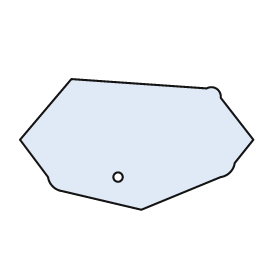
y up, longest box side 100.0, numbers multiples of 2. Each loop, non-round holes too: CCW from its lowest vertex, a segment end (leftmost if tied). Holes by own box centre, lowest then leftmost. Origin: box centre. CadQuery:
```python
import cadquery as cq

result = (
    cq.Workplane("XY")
    .moveTo(2.0, -28.0)
    .lineTo(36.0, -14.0)
    .threePointArc((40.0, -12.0), (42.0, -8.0))
    .lineTo(50.0, 2.0)
    .lineTo(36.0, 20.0)
    .threePointArc((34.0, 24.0), (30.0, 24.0))
    .lineTo(-28.0, 28.0)
    .lineTo(-50.0, 2.0)
    .lineTo(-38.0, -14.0)
    .threePointArc((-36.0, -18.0), (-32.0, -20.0))
    .close()
    .moveTo(-8.0, -14.0)
    .circle(2.0)
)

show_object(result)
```